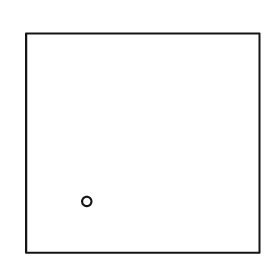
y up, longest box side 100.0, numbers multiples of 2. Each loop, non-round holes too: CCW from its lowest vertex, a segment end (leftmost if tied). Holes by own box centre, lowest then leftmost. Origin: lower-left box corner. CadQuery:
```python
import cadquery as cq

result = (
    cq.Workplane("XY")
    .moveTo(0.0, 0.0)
    .lineTo(100.0, 0.0)
    .lineTo(100.0, 94.0)
    .lineTo(0.0, 94.0)
    .close()
    .moveTo(26.0, 22.0)
    .circle(2.0)
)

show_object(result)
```